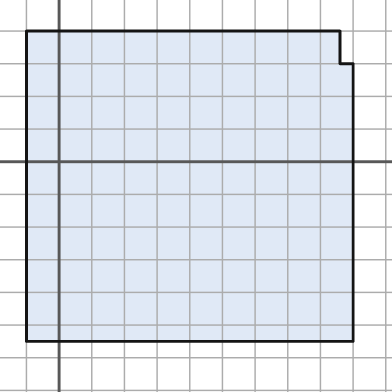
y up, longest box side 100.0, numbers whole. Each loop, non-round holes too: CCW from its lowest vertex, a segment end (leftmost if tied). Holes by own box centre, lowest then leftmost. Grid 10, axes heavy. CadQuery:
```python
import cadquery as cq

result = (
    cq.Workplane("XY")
    .moveTo(-10.0, -55.0)
    .lineTo(90.0, -55.0)
    .lineTo(90.0, 30.0)
    .lineTo(86.0, 30.0)
    .lineTo(86.0, 40.0)
    .lineTo(-10.0, 40.0)
    .close()
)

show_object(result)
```